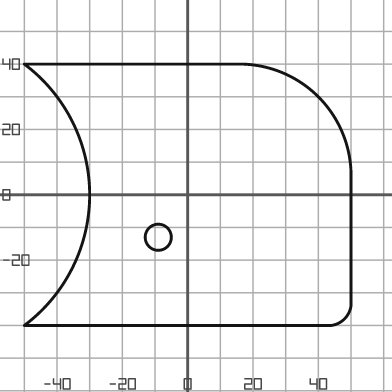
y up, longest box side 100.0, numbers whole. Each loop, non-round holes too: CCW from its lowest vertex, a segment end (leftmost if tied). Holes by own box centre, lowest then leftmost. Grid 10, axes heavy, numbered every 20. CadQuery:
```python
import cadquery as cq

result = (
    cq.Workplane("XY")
    .moveTo(-50.0, -40.0)
    .lineTo(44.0, -40.0)
    .threePointArc((48.0, -38.0), (50.0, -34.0))
    .lineTo(50.0, 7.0)
    .threePointArc((40.0, 30.0), (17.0, 40.0))
    .lineTo(-50.0, 40.0)
    .threePointArc((-30.0, 0.0), (-50.0, -40.0))
    .close()
    .moveTo(-9.0, -13.0)
    .circle(4.0)
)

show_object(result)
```